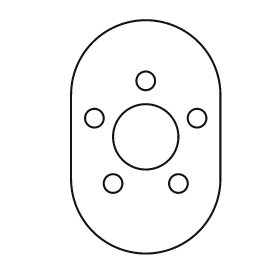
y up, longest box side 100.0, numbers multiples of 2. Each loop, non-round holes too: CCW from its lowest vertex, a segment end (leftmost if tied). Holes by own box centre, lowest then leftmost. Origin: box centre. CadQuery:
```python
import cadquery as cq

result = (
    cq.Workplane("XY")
    .moveTo(-32.0, -18.0)
    .threePointArc((0.0, -50.0), (32.0, -18.0))
    .lineTo(32.0, 18.0)
    .threePointArc((0.0, 50.0), (-32.0, 18.0))
    .close()
    .moveTo(-14.0, -20.0)
    .circle(4.0)
    .moveTo(14.0, -20.0)
    .circle(4.0)
    .moveTo(0.0, 0.0)
    .circle(14.0)
    .moveTo(-22.0, 8.0)
    .circle(4.0)
    .moveTo(22.0, 8.0)
    .circle(4.0)
    .moveTo(0.0, 24.0)
    .circle(4.0)
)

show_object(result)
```